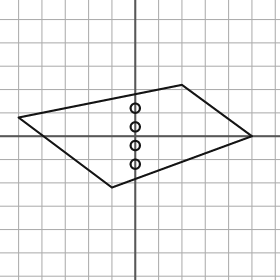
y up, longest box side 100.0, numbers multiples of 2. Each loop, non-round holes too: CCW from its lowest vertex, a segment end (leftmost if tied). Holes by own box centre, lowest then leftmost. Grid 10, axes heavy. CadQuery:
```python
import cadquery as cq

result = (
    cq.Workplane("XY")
    .moveTo(-10.0, -22.0)
    .lineTo(50.0, 0.0)
    .lineTo(20.0, 22.0)
    .lineTo(-50.0, 8.0)
    .close()
    .moveTo(0.0, -12.0)
    .circle(2.0)
    .moveTo(0.0, -4.0)
    .circle(2.0)
    .moveTo(0.0, 4.0)
    .circle(2.0)
    .moveTo(0.0, 12.0)
    .circle(2.0)
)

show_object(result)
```